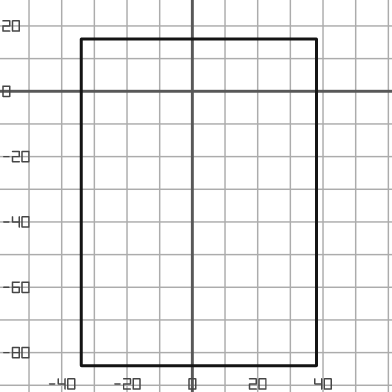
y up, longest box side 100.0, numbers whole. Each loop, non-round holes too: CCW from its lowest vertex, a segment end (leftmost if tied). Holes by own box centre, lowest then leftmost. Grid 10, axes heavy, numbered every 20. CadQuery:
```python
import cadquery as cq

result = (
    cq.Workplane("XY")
    .moveTo(-34.0, -84.0)
    .lineTo(38.0, -84.0)
    .lineTo(38.0, 16.0)
    .lineTo(-34.0, 16.0)
    .close()
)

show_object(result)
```